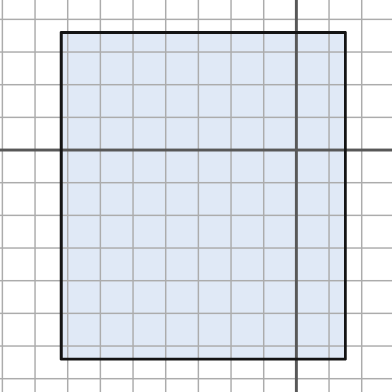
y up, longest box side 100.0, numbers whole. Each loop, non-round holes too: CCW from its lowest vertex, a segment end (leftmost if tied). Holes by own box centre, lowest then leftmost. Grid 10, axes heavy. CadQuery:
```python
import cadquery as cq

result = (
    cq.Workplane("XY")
    .moveTo(-72.0, -64.0)
    .lineTo(15.0, -64.0)
    .lineTo(15.0, 36.0)
    .lineTo(-72.0, 36.0)
    .close()
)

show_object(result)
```